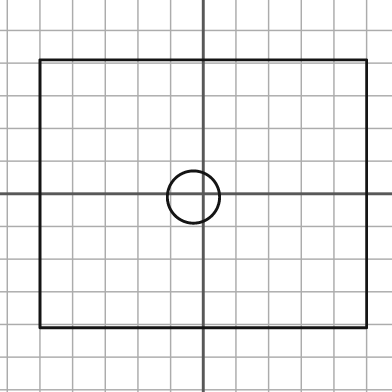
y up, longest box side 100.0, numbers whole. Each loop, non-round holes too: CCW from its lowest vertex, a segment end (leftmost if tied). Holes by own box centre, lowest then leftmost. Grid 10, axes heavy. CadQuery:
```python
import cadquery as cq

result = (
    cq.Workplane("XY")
    .moveTo(-50.0, -41.0)
    .lineTo(50.0, -41.0)
    .lineTo(50.0, 41.0)
    .lineTo(-50.0, 41.0)
    .close()
    .moveTo(-3.0, -1.0)
    .circle(8.0)
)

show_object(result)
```